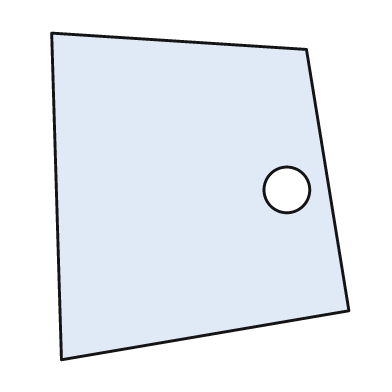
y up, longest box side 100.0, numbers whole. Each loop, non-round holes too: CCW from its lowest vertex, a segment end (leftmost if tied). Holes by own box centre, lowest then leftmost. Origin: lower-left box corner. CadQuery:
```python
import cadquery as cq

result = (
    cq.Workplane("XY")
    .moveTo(3.0, 0.0)
    .lineTo(91.0, 15.0)
    .lineTo(78.0, 95.0)
    .lineTo(0.0, 100.0)
    .close()
    .moveTo(72.0, 52.0)
    .circle(7.0)
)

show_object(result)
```